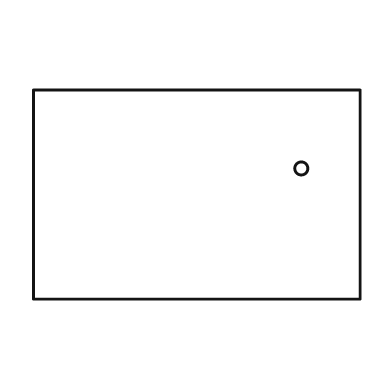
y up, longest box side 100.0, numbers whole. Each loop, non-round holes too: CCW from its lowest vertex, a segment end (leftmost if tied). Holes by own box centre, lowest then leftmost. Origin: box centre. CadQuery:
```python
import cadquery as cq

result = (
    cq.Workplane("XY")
    .moveTo(-50.0, -32.0)
    .lineTo(50.0, -32.0)
    .lineTo(50.0, 32.0)
    .lineTo(-50.0, 32.0)
    .close()
    .moveTo(32.0, 8.0)
    .circle(2.0)
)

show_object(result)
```